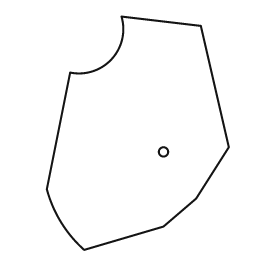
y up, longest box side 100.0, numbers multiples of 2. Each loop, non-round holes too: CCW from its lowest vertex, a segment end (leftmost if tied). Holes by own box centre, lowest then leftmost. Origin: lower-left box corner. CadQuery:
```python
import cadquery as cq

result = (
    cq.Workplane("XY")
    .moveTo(16.0, 0.0)
    .lineTo(50.0, 10.0)
    .lineTo(64.0, 22.0)
    .lineTo(78.0, 44.0)
    .lineTo(66.0, 96.0)
    .lineTo(32.0, 100.0)
    .threePointArc((28.0, 82.0), (10.0, 76.0))
    .lineTo(0.0, 26.0)
    .threePointArc((6.0, 12.0), (16.0, 0.0))
    .close()
    .moveTo(50.0, 42.0)
    .circle(2.0)
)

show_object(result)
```